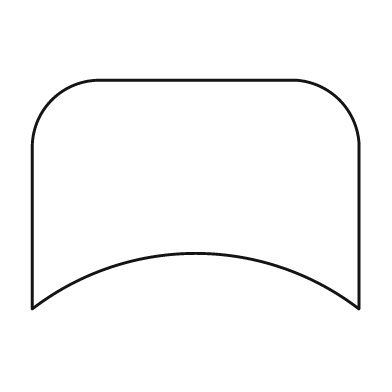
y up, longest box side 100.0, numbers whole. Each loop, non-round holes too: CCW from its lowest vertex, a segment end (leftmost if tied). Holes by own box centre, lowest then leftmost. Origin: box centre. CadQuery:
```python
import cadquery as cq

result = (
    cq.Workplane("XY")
    .moveTo(-50.0, -35.0)
    .threePointArc((0.0, -18.0), (50.0, -35.0))
    .lineTo(50.0, 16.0)
    .threePointArc((44.0, 29.0), (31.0, 35.0))
    .lineTo(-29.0, 35.0)
    .threePointArc((-44.0, 29.0), (-50.0, 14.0))
    .close()
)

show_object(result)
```